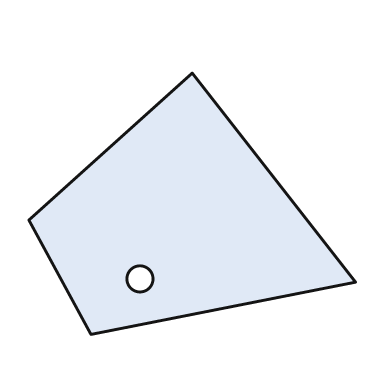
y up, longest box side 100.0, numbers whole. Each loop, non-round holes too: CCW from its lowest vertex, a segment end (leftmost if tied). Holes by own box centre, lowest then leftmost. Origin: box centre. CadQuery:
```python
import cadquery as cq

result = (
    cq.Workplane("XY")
    .moveTo(-31.0, -40.0)
    .lineTo(50.0, -24.0)
    .lineTo(0.0, 40.0)
    .lineTo(-50.0, -5.0)
    .close()
    .moveTo(-16.0, -23.0)
    .circle(4.0)
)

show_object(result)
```